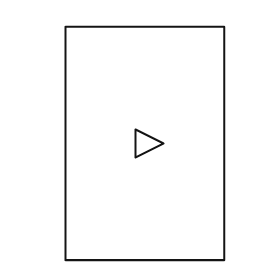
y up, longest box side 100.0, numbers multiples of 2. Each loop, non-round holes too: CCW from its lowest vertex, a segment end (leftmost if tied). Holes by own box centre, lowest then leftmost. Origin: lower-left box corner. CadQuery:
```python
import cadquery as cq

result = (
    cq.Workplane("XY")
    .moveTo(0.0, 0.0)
    .lineTo(68.0, 0.0)
    .lineTo(68.0, 100.0)
    .lineTo(0.0, 100.0)
    .close()
    .moveTo(30.0, 44.0)
    .lineTo(42.0, 50.0)
    .lineTo(30.0, 56.0)
    .close()
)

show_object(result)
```